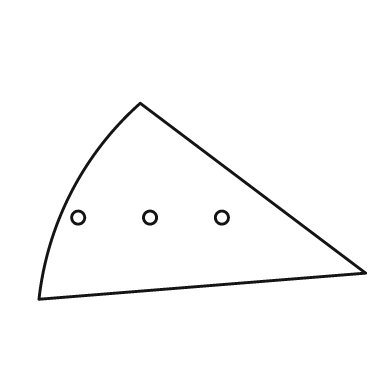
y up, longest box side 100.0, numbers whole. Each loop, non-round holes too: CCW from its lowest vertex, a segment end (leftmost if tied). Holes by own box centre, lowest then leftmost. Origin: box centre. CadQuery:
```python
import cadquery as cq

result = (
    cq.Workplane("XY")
    .moveTo(-50.0, -30.0)
    .lineTo(50.0, -22.0)
    .lineTo(-19.0, 30.0)
    .threePointArc((-40.0, 3.0), (-50.0, -30.0))
    .close()
    .moveTo(-38.0, -5.0)
    .circle(2.0)
    .moveTo(-16.0, -5.0)
    .circle(2.0)
    .moveTo(6.0, -5.0)
    .circle(2.0)
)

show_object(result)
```